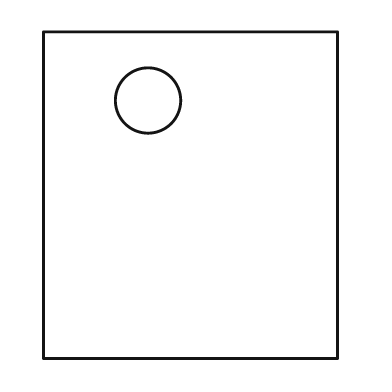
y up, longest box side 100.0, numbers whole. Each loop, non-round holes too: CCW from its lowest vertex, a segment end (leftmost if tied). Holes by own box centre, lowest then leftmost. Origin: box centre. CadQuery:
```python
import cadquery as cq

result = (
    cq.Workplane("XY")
    .moveTo(-45.0, -50.0)
    .lineTo(45.0, -50.0)
    .lineTo(45.0, 50.0)
    .lineTo(-45.0, 50.0)
    .close()
    .moveTo(-13.0, 29.0)
    .circle(10.0)
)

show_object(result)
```